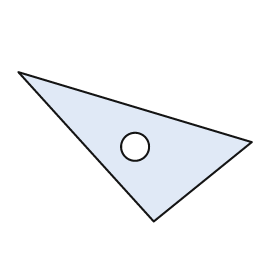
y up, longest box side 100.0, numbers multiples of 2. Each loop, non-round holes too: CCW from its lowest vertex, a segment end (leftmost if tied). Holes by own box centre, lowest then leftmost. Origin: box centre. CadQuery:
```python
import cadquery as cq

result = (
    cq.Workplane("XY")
    .moveTo(8.0, -32.0)
    .lineTo(50.0, 2.0)
    .lineTo(-50.0, 32.0)
    .close()
    .moveTo(0.0, 0.0)
    .circle(6.0)
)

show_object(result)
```